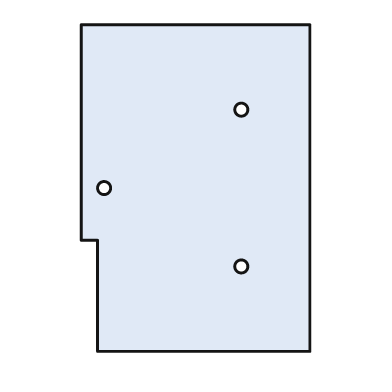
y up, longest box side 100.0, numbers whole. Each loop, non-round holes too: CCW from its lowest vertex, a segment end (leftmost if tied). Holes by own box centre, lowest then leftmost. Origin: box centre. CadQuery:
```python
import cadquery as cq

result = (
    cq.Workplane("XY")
    .moveTo(-30.0, -50.0)
    .lineTo(35.0, -50.0)
    .lineTo(35.0, 50.0)
    .lineTo(-35.0, 50.0)
    .lineTo(-35.0, -16.0)
    .lineTo(-30.0, -16.0)
    .close()
    .moveTo(14.0, -24.0)
    .circle(2.0)
    .moveTo(-28.0, 0.0)
    .circle(2.0)
    .moveTo(14.0, 24.0)
    .circle(2.0)
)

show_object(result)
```